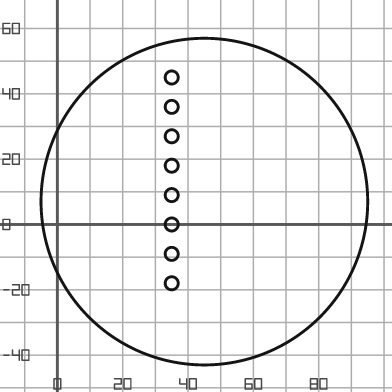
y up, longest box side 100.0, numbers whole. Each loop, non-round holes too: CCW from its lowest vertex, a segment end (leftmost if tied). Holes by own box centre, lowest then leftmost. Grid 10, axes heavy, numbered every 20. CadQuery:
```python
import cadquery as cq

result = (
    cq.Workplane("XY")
    .moveTo(45.0, 7.0)
    .circle(50.0)
    .moveTo(35.0, -18.0)
    .circle(2.0)
    .moveTo(35.0, -9.0)
    .circle(2.0)
    .moveTo(35.0, 0.0)
    .circle(2.0)
    .moveTo(35.0, 9.0)
    .circle(2.0)
    .moveTo(35.0, 18.0)
    .circle(2.0)
    .moveTo(35.0, 27.0)
    .circle(2.0)
    .moveTo(35.0, 36.0)
    .circle(2.0)
    .moveTo(35.0, 45.0)
    .circle(2.0)
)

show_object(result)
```